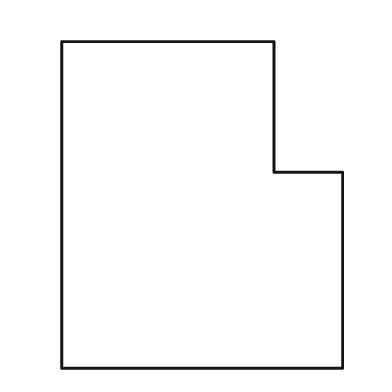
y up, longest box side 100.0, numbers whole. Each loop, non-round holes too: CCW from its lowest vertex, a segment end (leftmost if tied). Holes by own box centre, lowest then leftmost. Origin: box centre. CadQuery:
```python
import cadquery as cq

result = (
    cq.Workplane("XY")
    .moveTo(-43.0, -50.0)
    .lineTo(43.0, -50.0)
    .lineTo(43.0, 10.0)
    .lineTo(22.0, 10.0)
    .lineTo(22.0, 50.0)
    .lineTo(-43.0, 50.0)
    .close()
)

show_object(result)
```